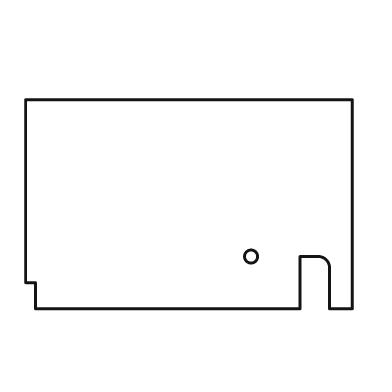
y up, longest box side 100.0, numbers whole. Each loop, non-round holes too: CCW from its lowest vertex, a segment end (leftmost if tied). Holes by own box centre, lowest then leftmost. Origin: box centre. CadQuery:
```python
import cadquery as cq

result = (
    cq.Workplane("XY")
    .moveTo(-47.0, -32.0)
    .lineTo(34.0, -32.0)
    .lineTo(34.0, -16.0)
    .lineTo(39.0, -16.0)
    .threePointArc((42.0, -17.0), (43.0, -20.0))
    .lineTo(43.0, -32.0)
    .lineTo(50.0, -32.0)
    .lineTo(50.0, 32.0)
    .lineTo(-50.0, 32.0)
    .lineTo(-50.0, -24.0)
    .lineTo(-47.0, -24.0)
    .close()
    .moveTo(19.0, -16.0)
    .circle(2.0)
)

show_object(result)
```